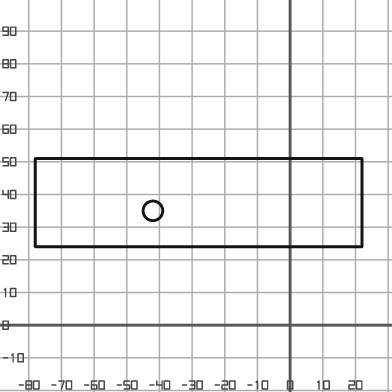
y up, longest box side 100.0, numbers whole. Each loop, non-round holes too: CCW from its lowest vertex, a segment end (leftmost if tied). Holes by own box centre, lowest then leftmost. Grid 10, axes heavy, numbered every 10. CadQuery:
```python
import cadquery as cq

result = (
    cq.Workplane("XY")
    .moveTo(-78.0, 24.0)
    .lineTo(22.0, 24.0)
    .lineTo(22.0, 51.0)
    .lineTo(-78.0, 51.0)
    .close()
    .moveTo(-42.0, 35.0)
    .circle(3.0)
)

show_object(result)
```